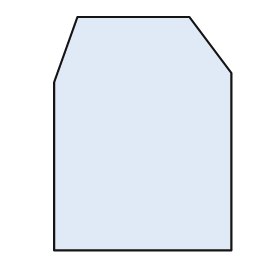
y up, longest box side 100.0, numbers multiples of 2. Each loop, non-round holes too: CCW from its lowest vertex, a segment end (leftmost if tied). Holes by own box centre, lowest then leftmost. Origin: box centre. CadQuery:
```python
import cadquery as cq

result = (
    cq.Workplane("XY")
    .moveTo(-38.0, -50.0)
    .lineTo(38.0, -50.0)
    .lineTo(38.0, 26.0)
    .lineTo(20.0, 50.0)
    .lineTo(-28.0, 50.0)
    .lineTo(-38.0, 22.0)
    .close()
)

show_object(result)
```